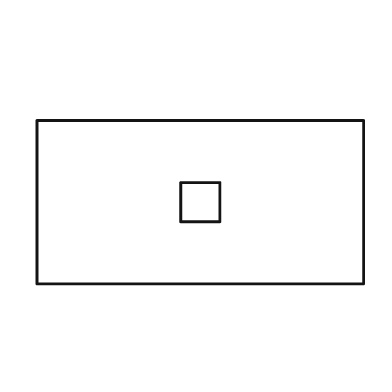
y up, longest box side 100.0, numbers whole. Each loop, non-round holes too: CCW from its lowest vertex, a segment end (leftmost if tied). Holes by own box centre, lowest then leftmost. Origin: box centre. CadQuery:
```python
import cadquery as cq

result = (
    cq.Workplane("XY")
    .moveTo(-50.0, -25.0)
    .lineTo(50.0, -25.0)
    .lineTo(50.0, 25.0)
    .lineTo(-50.0, 25.0)
    .close()
    .moveTo(-6.0, -6.0)
    .lineTo(6.0, -6.0)
    .lineTo(6.0, 6.0)
    .lineTo(-6.0, 6.0)
    .close()
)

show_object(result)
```